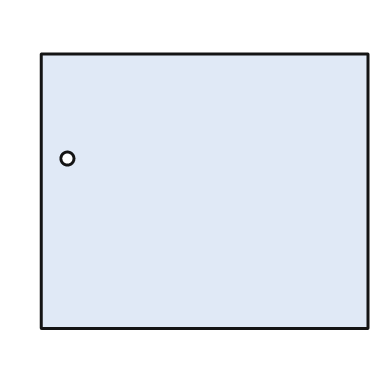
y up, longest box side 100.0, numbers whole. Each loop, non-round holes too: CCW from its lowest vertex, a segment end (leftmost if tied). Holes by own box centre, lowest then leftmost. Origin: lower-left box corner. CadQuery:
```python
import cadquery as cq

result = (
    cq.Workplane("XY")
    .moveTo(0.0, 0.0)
    .lineTo(100.0, 0.0)
    .lineTo(100.0, 84.0)
    .lineTo(0.0, 84.0)
    .close()
    .moveTo(8.0, 52.0)
    .circle(2.0)
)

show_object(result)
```